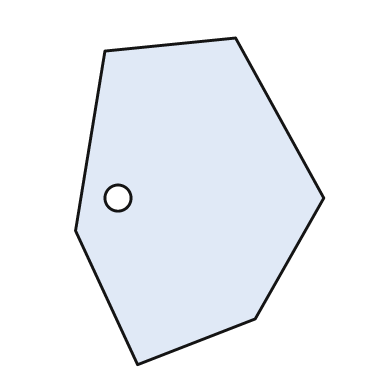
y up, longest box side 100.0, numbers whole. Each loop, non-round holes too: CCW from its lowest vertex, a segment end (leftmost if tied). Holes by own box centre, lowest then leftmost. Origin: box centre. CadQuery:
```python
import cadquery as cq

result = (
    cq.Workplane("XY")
    .moveTo(-19.0, -50.0)
    .lineTo(17.0, -36.0)
    .lineTo(38.0, 1.0)
    .lineTo(11.0, 50.0)
    .lineTo(-29.0, 46.0)
    .lineTo(-38.0, -9.0)
    .close()
    .moveTo(-25.0, 1.0)
    .circle(4.0)
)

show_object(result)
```